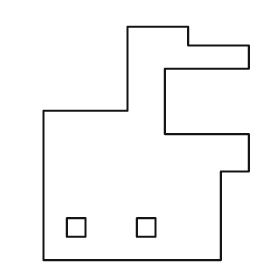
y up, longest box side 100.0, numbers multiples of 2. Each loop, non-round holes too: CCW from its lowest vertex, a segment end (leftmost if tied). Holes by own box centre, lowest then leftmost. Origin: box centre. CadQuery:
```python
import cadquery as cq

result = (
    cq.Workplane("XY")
    .moveTo(-44.0, -50.0)
    .lineTo(32.0, -50.0)
    .lineTo(32.0, -12.0)
    .lineTo(44.0, -12.0)
    .lineTo(44.0, 4.0)
    .lineTo(8.0, 4.0)
    .lineTo(8.0, 32.0)
    .lineTo(44.0, 32.0)
    .lineTo(44.0, 42.0)
    .lineTo(18.0, 42.0)
    .lineTo(18.0, 50.0)
    .lineTo(-8.0, 50.0)
    .lineTo(-8.0, 14.0)
    .lineTo(-44.0, 14.0)
    .close()
    .moveTo(-34.0, -40.0)
    .lineTo(-26.0, -40.0)
    .lineTo(-26.0, -32.0)
    .lineTo(-34.0, -32.0)
    .close()
    .moveTo(-4.0, -40.0)
    .lineTo(4.0, -40.0)
    .lineTo(4.0, -32.0)
    .lineTo(-4.0, -32.0)
    .close()
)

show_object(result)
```